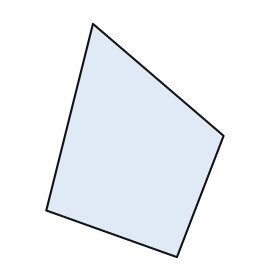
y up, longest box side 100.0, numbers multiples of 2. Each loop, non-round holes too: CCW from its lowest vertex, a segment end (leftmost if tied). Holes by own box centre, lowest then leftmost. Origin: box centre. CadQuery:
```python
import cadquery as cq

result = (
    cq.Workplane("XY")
    .moveTo(18.0, -50.0)
    .lineTo(38.0, 2.0)
    .lineTo(-18.0, 50.0)
    .lineTo(-38.0, -30.0)
    .close()
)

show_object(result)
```